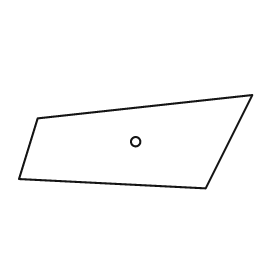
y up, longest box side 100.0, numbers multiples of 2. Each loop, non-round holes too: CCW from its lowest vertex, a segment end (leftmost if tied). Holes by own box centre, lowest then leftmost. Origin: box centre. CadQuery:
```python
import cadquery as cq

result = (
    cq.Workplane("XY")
    .moveTo(30.0, -20.0)
    .lineTo(50.0, 20.0)
    .lineTo(-42.0, 10.0)
    .lineTo(-50.0, -16.0)
    .close()
    .moveTo(0.0, 0.0)
    .circle(2.0)
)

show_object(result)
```